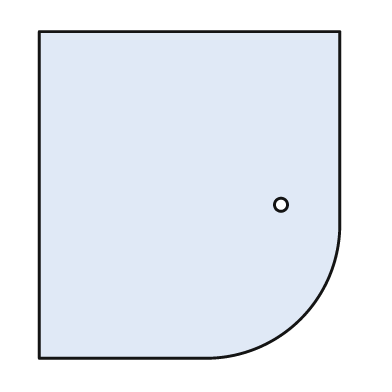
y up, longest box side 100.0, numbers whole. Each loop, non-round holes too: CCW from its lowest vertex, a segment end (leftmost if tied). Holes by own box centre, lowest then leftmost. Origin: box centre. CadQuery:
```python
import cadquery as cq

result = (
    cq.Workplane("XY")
    .moveTo(-46.0, -50.0)
    .lineTo(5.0, -50.0)
    .threePointArc((34.0, -38.0), (46.0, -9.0))
    .lineTo(46.0, 50.0)
    .lineTo(-46.0, 50.0)
    .close()
    .moveTo(28.0, -3.0)
    .circle(2.0)
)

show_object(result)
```